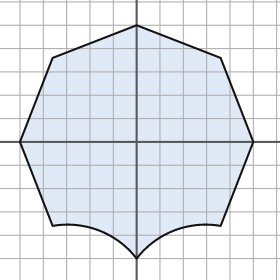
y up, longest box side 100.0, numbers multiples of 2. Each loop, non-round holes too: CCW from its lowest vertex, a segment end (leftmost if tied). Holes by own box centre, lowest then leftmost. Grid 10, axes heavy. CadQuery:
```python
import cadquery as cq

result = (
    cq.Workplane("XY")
    .moveTo(0.0, -50.0)
    .threePointArc((16.0, -38.0), (36.0, -36.0))
    .lineTo(50.0, 0.0)
    .lineTo(36.0, 36.0)
    .lineTo(0.0, 50.0)
    .lineTo(-36.0, 36.0)
    .lineTo(-50.0, 0.0)
    .lineTo(-36.0, -36.0)
    .threePointArc((-16.0, -38.0), (0.0, -50.0))
    .close()
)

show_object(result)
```